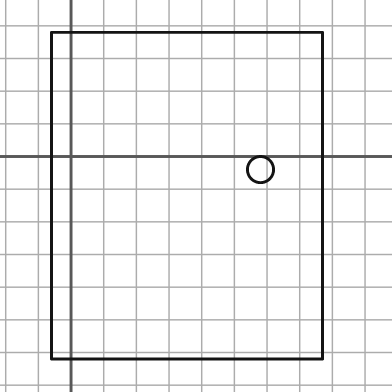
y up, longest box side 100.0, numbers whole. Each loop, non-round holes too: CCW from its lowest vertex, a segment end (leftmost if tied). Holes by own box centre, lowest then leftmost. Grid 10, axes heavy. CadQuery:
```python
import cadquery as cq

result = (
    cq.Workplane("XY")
    .moveTo(-6.0, -62.0)
    .lineTo(77.0, -62.0)
    .lineTo(77.0, 38.0)
    .lineTo(-6.0, 38.0)
    .close()
    .moveTo(58.0, -4.0)
    .circle(4.0)
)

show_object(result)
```